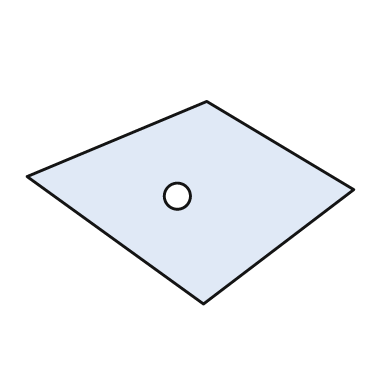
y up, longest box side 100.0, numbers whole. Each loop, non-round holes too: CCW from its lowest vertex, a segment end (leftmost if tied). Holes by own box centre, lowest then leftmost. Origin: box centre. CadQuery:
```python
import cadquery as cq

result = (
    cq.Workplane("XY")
    .moveTo(4.0, -31.0)
    .lineTo(50.0, 4.0)
    .lineTo(5.0, 31.0)
    .lineTo(-50.0, 8.0)
    .close()
    .moveTo(-4.0, 2.0)
    .circle(4.0)
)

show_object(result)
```